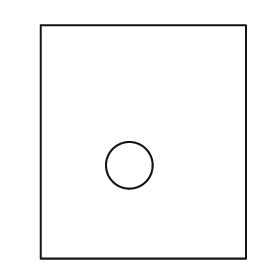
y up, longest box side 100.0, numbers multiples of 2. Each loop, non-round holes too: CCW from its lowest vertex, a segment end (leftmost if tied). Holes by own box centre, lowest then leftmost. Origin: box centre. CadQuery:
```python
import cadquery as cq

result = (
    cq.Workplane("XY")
    .moveTo(-44.0, -50.0)
    .lineTo(44.0, -50.0)
    .lineTo(44.0, 50.0)
    .lineTo(-44.0, 50.0)
    .close()
    .moveTo(-6.0, -10.0)
    .circle(10.0)
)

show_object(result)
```